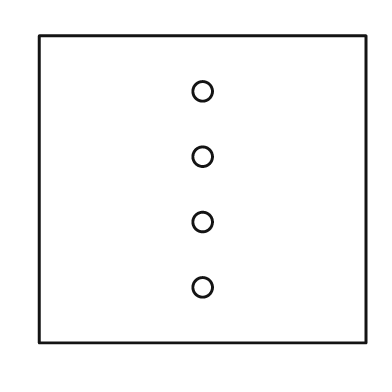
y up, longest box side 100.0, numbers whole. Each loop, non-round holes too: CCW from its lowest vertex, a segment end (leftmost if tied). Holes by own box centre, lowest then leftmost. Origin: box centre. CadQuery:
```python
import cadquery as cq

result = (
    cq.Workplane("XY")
    .moveTo(-50.0, -47.0)
    .lineTo(50.0, -47.0)
    .lineTo(50.0, 47.0)
    .lineTo(-50.0, 47.0)
    .close()
    .moveTo(0.0, -30.0)
    .circle(3.0)
    .moveTo(0.0, -10.0)
    .circle(3.0)
    .moveTo(0.0, 10.0)
    .circle(3.0)
    .moveTo(0.0, 30.0)
    .circle(3.0)
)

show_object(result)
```